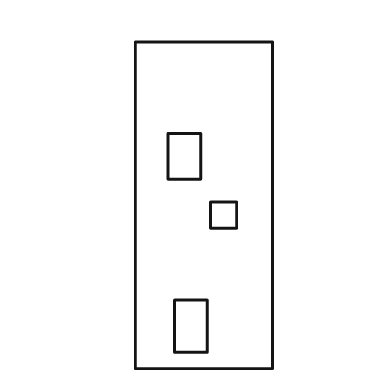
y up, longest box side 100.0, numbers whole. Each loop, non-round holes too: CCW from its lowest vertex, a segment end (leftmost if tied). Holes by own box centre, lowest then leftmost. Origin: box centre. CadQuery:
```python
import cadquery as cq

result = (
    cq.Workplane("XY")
    .moveTo(-21.0, -50.0)
    .lineTo(21.0, -50.0)
    .lineTo(21.0, 50.0)
    .lineTo(-21.0, 50.0)
    .close()
    .moveTo(-9.0, -45.0)
    .lineTo(1.0, -45.0)
    .lineTo(1.0, -29.0)
    .lineTo(-9.0, -29.0)
    .close()
    .moveTo(2.0, -7.0)
    .lineTo(10.0, -7.0)
    .lineTo(10.0, 1.0)
    .lineTo(2.0, 1.0)
    .close()
    .moveTo(-11.0, 8.0)
    .lineTo(-1.0, 8.0)
    .lineTo(-1.0, 22.0)
    .lineTo(-11.0, 22.0)
    .close()
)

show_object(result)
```